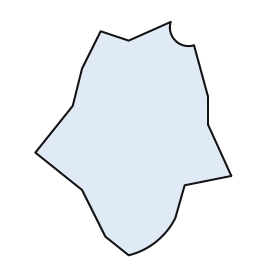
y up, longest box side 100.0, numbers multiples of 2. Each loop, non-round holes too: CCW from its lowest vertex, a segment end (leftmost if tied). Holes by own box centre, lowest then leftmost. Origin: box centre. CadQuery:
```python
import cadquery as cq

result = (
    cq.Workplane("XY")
    .moveTo(-2.0, -50.0)
    .threePointArc((10.0, -44.0), (18.0, -34.0))
    .lineTo(22.0, -20.0)
    .lineTo(42.0, -16.0)
    .lineTo(32.0, 6.0)
    .lineTo(32.0, 18.0)
    .lineTo(26.0, 40.0)
    .threePointArc((18.0, 42.0), (16.0, 50.0))
    .lineTo(-2.0, 42.0)
    .lineTo(-14.0, 46.0)
    .lineTo(-22.0, 30.0)
    .lineTo(-26.0, 14.0)
    .lineTo(-42.0, -6.0)
    .lineTo(-22.0, -22.0)
    .lineTo(-12.0, -42.0)
    .close()
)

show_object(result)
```